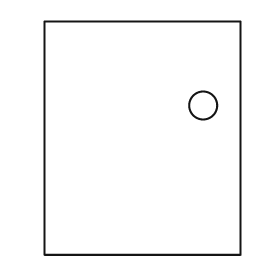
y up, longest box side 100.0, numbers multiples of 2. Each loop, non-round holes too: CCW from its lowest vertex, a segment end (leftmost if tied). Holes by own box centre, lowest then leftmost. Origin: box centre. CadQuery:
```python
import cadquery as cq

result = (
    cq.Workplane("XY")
    .moveTo(-42.0, -50.0)
    .lineTo(42.0, -50.0)
    .lineTo(42.0, 50.0)
    .lineTo(-42.0, 50.0)
    .close()
    .moveTo(26.0, 14.0)
    .circle(6.0)
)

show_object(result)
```